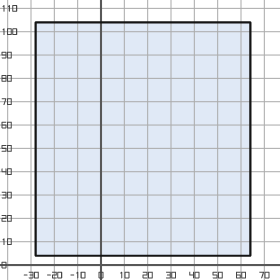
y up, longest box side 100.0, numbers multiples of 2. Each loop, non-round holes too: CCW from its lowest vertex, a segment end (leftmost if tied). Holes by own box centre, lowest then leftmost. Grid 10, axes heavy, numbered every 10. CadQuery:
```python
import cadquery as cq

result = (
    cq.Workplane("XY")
    .moveTo(-28.0, 4.0)
    .lineTo(64.0, 4.0)
    .lineTo(64.0, 104.0)
    .lineTo(-28.0, 104.0)
    .close()
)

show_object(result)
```